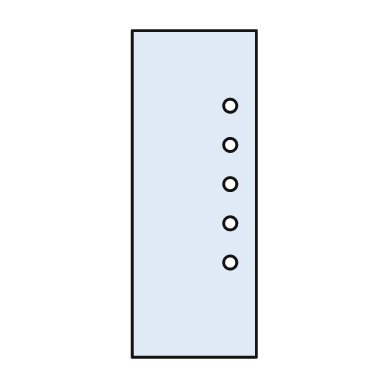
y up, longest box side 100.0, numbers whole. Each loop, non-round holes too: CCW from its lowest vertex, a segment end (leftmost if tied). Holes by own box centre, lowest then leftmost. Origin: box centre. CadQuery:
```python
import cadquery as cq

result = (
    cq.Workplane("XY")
    .moveTo(-19.0, -50.0)
    .lineTo(19.0, -50.0)
    .lineTo(19.0, 50.0)
    .lineTo(-19.0, 50.0)
    .close()
    .moveTo(11.0, -21.0)
    .circle(2.0)
    .moveTo(11.0, -9.0)
    .circle(2.0)
    .moveTo(11.0, 3.0)
    .circle(2.0)
    .moveTo(11.0, 15.0)
    .circle(2.0)
    .moveTo(11.0, 27.0)
    .circle(2.0)
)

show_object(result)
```